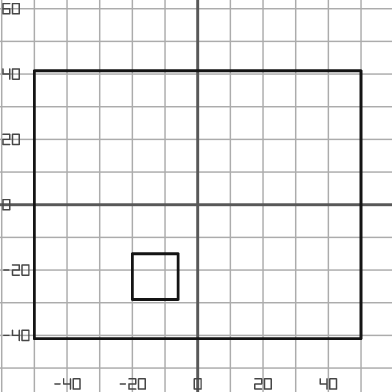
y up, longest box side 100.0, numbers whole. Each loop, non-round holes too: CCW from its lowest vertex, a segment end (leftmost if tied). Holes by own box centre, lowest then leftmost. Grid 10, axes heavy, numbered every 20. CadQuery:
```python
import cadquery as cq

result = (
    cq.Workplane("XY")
    .moveTo(-50.0, -41.0)
    .lineTo(50.0, -41.0)
    .lineTo(50.0, 41.0)
    .lineTo(-50.0, 41.0)
    .close()
    .moveTo(-20.0, -29.0)
    .lineTo(-6.0, -29.0)
    .lineTo(-6.0, -15.0)
    .lineTo(-20.0, -15.0)
    .close()
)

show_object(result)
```